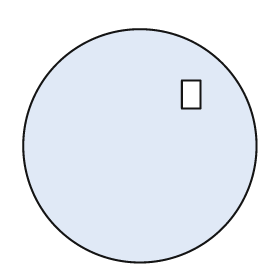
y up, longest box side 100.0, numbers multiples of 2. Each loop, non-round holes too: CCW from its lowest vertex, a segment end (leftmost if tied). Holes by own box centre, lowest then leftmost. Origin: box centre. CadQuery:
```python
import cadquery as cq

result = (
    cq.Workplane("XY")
    .moveTo(0.0, 0.0)
    .circle(50.0)
    .moveTo(18.0, 16.0)
    .lineTo(26.0, 16.0)
    .lineTo(26.0, 28.0)
    .lineTo(18.0, 28.0)
    .close()
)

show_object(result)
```